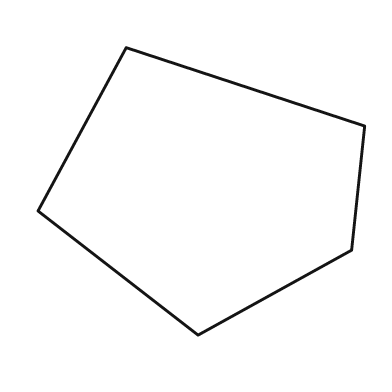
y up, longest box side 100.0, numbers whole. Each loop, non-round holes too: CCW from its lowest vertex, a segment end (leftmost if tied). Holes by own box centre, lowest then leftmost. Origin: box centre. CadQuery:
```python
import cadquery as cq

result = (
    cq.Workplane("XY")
    .moveTo(-1.0, -44.0)
    .lineTo(46.0, -18.0)
    .lineTo(50.0, 20.0)
    .lineTo(-23.0, 44.0)
    .lineTo(-50.0, -6.0)
    .close()
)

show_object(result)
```